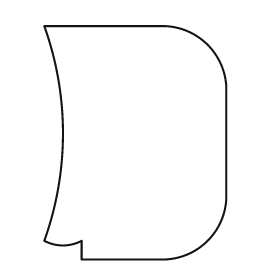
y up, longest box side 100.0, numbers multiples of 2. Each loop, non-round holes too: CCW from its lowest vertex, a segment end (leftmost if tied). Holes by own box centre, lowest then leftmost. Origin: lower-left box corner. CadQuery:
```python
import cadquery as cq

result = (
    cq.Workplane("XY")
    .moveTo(16.0, 0.0)
    .lineTo(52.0, 0.0)
    .threePointArc((70.0, 8.0), (78.0, 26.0))
    .lineTo(78.0, 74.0)
    .threePointArc((70.0, 92.0), (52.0, 100.0))
    .lineTo(0.0, 100.0)
    .threePointArc((8.0, 54.0), (0.0, 8.0))
    .threePointArc((8.0, 6.0), (16.0, 8.0))
    .close()
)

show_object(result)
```